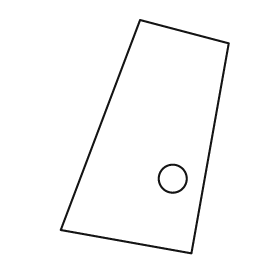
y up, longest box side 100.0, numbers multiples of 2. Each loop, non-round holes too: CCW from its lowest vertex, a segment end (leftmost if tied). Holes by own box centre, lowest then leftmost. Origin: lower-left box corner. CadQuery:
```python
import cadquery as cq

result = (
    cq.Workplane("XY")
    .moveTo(56.0, 0.0)
    .lineTo(72.0, 90.0)
    .lineTo(34.0, 100.0)
    .lineTo(0.0, 10.0)
    .close()
    .moveTo(48.0, 32.0)
    .circle(6.0)
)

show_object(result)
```